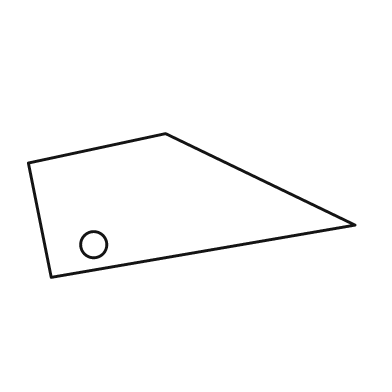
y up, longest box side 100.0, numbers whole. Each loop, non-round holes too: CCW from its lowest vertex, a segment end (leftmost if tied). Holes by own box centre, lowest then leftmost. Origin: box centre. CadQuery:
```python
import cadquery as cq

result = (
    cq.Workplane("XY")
    .moveTo(-43.0, -22.0)
    .lineTo(50.0, -6.0)
    .lineTo(-8.0, 22.0)
    .lineTo(-50.0, 13.0)
    .close()
    .moveTo(-30.0, -12.0)
    .circle(4.0)
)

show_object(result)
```